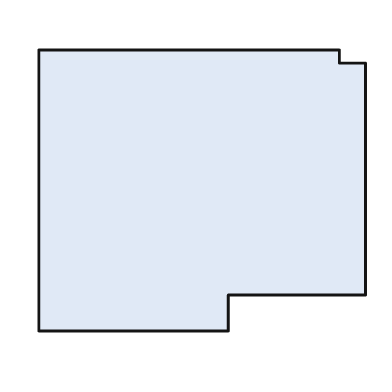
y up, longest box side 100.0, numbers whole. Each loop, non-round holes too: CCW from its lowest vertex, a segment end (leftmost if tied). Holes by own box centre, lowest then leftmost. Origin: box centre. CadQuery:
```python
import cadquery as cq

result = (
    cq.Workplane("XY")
    .moveTo(-50.0, -43.0)
    .lineTo(8.0, -43.0)
    .lineTo(8.0, -32.0)
    .lineTo(50.0, -32.0)
    .lineTo(50.0, 39.0)
    .lineTo(42.0, 39.0)
    .lineTo(42.0, 43.0)
    .lineTo(-50.0, 43.0)
    .close()
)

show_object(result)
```